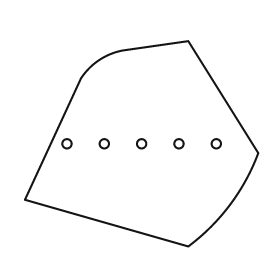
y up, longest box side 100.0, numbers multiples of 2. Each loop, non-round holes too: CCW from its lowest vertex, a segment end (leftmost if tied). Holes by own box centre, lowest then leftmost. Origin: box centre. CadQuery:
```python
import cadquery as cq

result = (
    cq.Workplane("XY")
    .moveTo(20.0, -44.0)
    .threePointArc((38.0, -26.0), (50.0, -4.0))
    .lineTo(20.0, 44.0)
    .lineTo(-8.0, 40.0)
    .threePointArc((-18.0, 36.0), (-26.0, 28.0))
    .lineTo(-50.0, -24.0)
    .close()
    .moveTo(-32.0, 0.0)
    .circle(2.0)
    .moveTo(-16.0, 0.0)
    .circle(2.0)
    .moveTo(0.0, 0.0)
    .circle(2.0)
    .moveTo(16.0, 0.0)
    .circle(2.0)
    .moveTo(32.0, 0.0)
    .circle(2.0)
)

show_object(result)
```